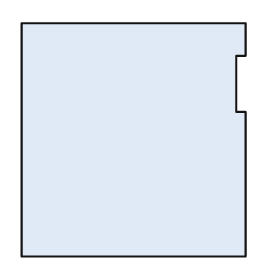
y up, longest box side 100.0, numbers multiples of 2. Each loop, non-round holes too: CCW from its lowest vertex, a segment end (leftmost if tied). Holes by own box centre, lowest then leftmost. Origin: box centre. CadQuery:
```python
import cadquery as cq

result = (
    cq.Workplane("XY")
    .moveTo(-48.0, -50.0)
    .lineTo(48.0, -50.0)
    .lineTo(48.0, 12.0)
    .lineTo(44.0, 12.0)
    .lineTo(44.0, 36.0)
    .lineTo(48.0, 36.0)
    .lineTo(48.0, 50.0)
    .lineTo(-48.0, 50.0)
    .close()
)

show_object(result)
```